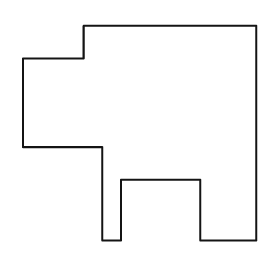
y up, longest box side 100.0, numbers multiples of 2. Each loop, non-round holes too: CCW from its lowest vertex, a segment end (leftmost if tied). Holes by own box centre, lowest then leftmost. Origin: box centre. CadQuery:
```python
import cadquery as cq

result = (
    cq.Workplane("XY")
    .moveTo(-16.0, -46.0)
    .lineTo(-8.0, -46.0)
    .lineTo(-8.0, -20.0)
    .lineTo(26.0, -20.0)
    .lineTo(26.0, -46.0)
    .lineTo(50.0, -46.0)
    .lineTo(50.0, 46.0)
    .lineTo(-24.0, 46.0)
    .lineTo(-24.0, 32.0)
    .lineTo(-50.0, 32.0)
    .lineTo(-50.0, -6.0)
    .lineTo(-16.0, -6.0)
    .close()
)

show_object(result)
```